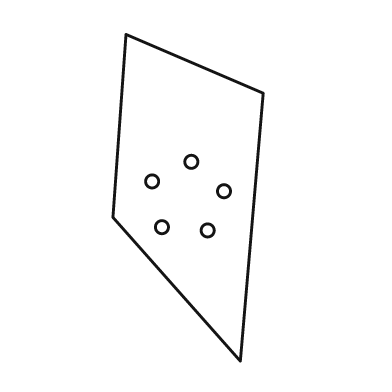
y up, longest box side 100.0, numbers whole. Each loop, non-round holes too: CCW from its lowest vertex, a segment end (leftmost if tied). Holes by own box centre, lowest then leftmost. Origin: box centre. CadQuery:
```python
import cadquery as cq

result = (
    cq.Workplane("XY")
    .moveTo(16.0, -50.0)
    .lineTo(23.0, 32.0)
    .lineTo(-19.0, 50.0)
    .lineTo(-23.0, -6.0)
    .close()
    .moveTo(6.0, -10.0)
    .circle(2.0)
    .moveTo(-8.0, -9.0)
    .circle(2.0)
    .moveTo(11.0, 2.0)
    .circle(2.0)
    .moveTo(-11.0, 5.0)
    .circle(2.0)
    .moveTo(1.0, 11.0)
    .circle(2.0)
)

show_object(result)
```